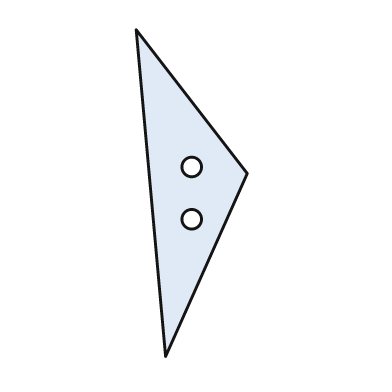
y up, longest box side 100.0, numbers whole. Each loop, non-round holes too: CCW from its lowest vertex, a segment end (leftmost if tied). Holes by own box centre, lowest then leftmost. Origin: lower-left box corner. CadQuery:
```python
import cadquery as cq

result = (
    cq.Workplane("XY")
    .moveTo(9.0, 0.0)
    .lineTo(34.0, 56.0)
    .lineTo(0.0, 100.0)
    .close()
    .moveTo(17.0, 42.0)
    .circle(3.0)
    .moveTo(17.0, 58.0)
    .circle(3.0)
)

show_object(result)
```